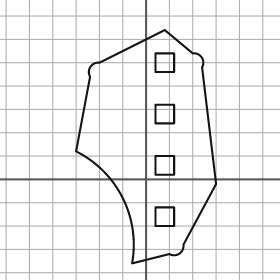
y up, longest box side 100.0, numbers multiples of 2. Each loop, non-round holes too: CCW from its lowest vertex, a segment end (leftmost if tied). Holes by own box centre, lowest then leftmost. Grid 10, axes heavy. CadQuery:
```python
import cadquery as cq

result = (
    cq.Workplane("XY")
    .moveTo(-6.0, -36.0)
    .lineTo(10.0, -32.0)
    .threePointArc((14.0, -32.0), (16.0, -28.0))
    .lineTo(30.0, -2.0)
    .lineTo(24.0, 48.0)
    .threePointArc((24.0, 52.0), (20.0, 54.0))
    .lineTo(8.0, 64.0)
    .lineTo(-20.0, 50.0)
    .threePointArc((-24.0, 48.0), (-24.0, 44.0))
    .lineTo(-30.0, 12.0)
    .threePointArc((-10.0, -8.0), (-6.0, -36.0))
    .close()
    .moveTo(4.0, -20.0)
    .lineTo(12.0, -20.0)
    .lineTo(12.0, -12.0)
    .lineTo(4.0, -12.0)
    .close()
    .moveTo(4.0, 2.0)
    .lineTo(12.0, 2.0)
    .lineTo(12.0, 10.0)
    .lineTo(4.0, 10.0)
    .close()
    .moveTo(4.0, 24.0)
    .lineTo(12.0, 24.0)
    .lineTo(12.0, 32.0)
    .lineTo(4.0, 32.0)
    .close()
    .moveTo(4.0, 46.0)
    .lineTo(12.0, 46.0)
    .lineTo(12.0, 54.0)
    .lineTo(4.0, 54.0)
    .close()
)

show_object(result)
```